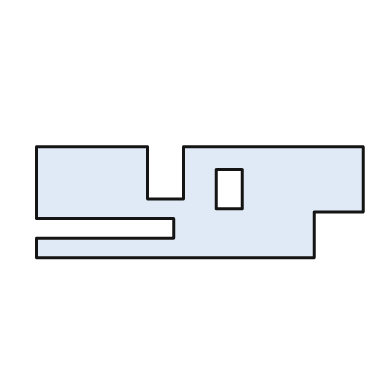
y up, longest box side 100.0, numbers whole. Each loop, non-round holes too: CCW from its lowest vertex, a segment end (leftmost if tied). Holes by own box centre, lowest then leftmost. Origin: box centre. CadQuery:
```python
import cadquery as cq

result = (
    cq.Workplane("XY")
    .moveTo(-50.0, -17.0)
    .lineTo(35.0, -17.0)
    .lineTo(35.0, -3.0)
    .lineTo(50.0, -3.0)
    .lineTo(50.0, 17.0)
    .lineTo(-5.0, 17.0)
    .lineTo(-5.0, 1.0)
    .lineTo(-16.0, 1.0)
    .lineTo(-16.0, 17.0)
    .lineTo(-50.0, 17.0)
    .lineTo(-50.0, -5.0)
    .lineTo(-8.0, -5.0)
    .lineTo(-8.0, -11.0)
    .lineTo(-50.0, -11.0)
    .close()
    .moveTo(5.0, -2.0)
    .lineTo(13.0, -2.0)
    .lineTo(13.0, 10.0)
    .lineTo(5.0, 10.0)
    .close()
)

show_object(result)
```